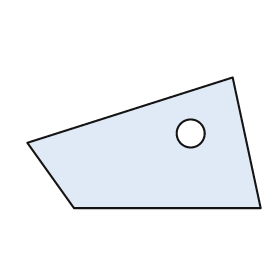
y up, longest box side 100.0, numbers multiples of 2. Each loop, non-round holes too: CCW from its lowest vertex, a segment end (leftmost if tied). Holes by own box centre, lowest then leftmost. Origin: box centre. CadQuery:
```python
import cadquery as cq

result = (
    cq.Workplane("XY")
    .moveTo(-30.0, -28.0)
    .lineTo(50.0, -28.0)
    .lineTo(38.0, 28.0)
    .lineTo(-50.0, 0.0)
    .close()
    .moveTo(20.0, 4.0)
    .circle(6.0)
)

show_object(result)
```